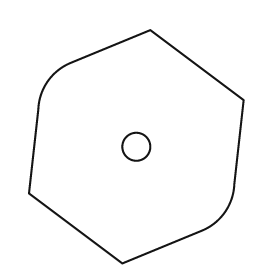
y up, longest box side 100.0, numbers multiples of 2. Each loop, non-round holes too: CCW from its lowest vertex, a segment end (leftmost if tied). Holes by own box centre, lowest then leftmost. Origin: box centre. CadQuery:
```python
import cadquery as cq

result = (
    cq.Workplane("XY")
    .moveTo(-6.0, -50.0)
    .lineTo(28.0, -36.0)
    .threePointArc((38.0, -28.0), (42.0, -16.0))
    .lineTo(46.0, 20.0)
    .lineTo(6.0, 50.0)
    .lineTo(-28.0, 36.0)
    .threePointArc((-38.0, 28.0), (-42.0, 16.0))
    .lineTo(-46.0, -20.0)
    .close()
    .moveTo(0.0, 0.0)
    .circle(6.0)
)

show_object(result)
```